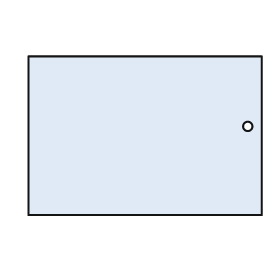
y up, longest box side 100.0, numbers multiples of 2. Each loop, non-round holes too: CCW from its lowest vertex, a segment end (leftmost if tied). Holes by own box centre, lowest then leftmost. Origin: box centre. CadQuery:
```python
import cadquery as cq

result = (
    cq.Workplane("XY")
    .moveTo(-50.0, -34.0)
    .lineTo(50.0, -34.0)
    .lineTo(50.0, 34.0)
    .lineTo(-50.0, 34.0)
    .close()
    .moveTo(44.0, 4.0)
    .circle(2.0)
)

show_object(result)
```